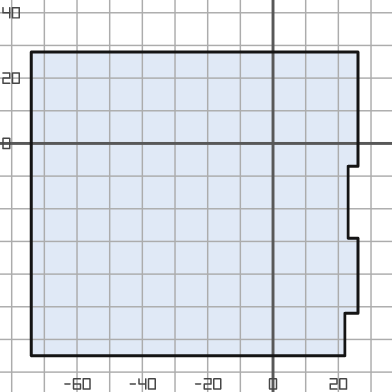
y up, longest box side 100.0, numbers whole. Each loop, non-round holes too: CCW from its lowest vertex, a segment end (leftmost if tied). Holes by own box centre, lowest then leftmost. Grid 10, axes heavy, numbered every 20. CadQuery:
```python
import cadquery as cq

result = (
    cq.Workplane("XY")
    .moveTo(-74.0, -65.0)
    .lineTo(22.0, -65.0)
    .lineTo(22.0, -52.0)
    .lineTo(26.0, -52.0)
    .lineTo(26.0, -29.0)
    .lineTo(23.0, -29.0)
    .lineTo(23.0, -7.0)
    .lineTo(26.0, -7.0)
    .lineTo(26.0, 28.0)
    .lineTo(-74.0, 28.0)
    .close()
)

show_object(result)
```